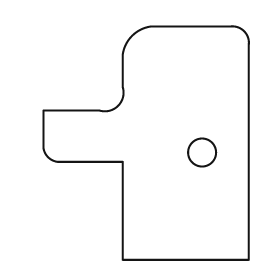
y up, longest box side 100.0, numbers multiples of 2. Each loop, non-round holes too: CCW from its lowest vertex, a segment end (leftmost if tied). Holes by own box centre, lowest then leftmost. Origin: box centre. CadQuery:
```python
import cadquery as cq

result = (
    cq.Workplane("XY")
    .moveTo(-10.0, -50.0)
    .lineTo(44.0, -50.0)
    .lineTo(44.0, 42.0)
    .threePointArc((42.0, 48.0), (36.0, 50.0))
    .lineTo(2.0, 50.0)
    .threePointArc((-6.0, 46.0), (-10.0, 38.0))
    .lineTo(-10.0, 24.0)
    .threePointArc((-12.0, 16.0), (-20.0, 14.0))
    .lineTo(-44.0, 14.0)
    .lineTo(-44.0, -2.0)
    .threePointArc((-42.0, -6.0), (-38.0, -8.0))
    .lineTo(-10.0, -8.0)
    .close()
    .moveTo(24.0, -4.0)
    .circle(6.0)
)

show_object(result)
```